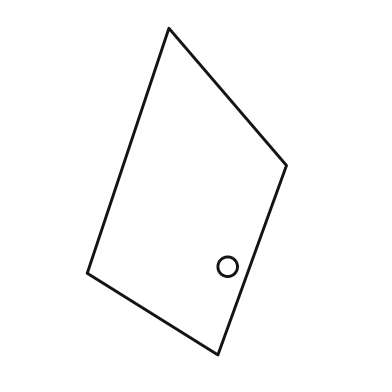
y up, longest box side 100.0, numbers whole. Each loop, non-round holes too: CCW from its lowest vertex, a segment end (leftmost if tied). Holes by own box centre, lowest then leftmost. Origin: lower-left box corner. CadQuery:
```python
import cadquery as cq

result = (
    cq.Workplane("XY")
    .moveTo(40.0, 0.0)
    .lineTo(61.0, 58.0)
    .lineTo(25.0, 100.0)
    .lineTo(0.0, 25.0)
    .close()
    .moveTo(43.0, 27.0)
    .circle(3.0)
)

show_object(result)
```